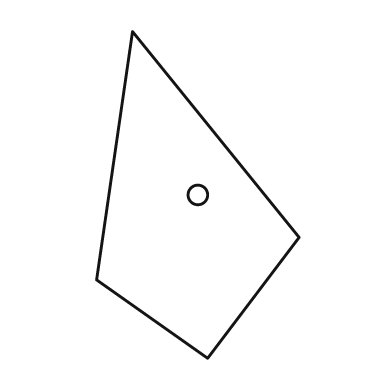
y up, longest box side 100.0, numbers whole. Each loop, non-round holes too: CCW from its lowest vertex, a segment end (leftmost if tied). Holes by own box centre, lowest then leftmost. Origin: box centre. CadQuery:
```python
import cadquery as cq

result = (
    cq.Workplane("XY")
    .moveTo(3.0, -50.0)
    .lineTo(31.0, -13.0)
    .lineTo(-20.0, 50.0)
    .lineTo(-31.0, -26.0)
    .close()
    .moveTo(0.0, 0.0)
    .circle(3.0)
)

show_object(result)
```